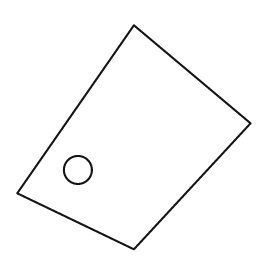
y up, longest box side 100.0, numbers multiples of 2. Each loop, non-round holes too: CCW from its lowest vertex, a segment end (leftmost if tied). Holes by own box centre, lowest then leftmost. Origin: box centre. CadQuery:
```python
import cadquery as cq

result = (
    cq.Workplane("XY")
    .moveTo(0.0, -48.0)
    .lineTo(50.0, 6.0)
    .lineTo(0.0, 48.0)
    .lineTo(-50.0, -24.0)
    .close()
    .moveTo(-24.0, -14.0)
    .circle(6.0)
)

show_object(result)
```